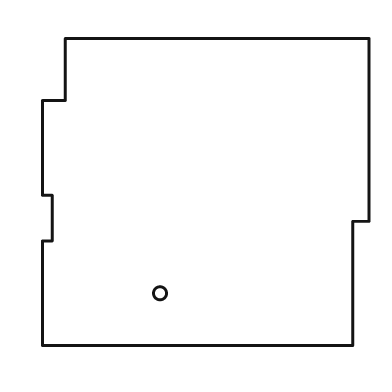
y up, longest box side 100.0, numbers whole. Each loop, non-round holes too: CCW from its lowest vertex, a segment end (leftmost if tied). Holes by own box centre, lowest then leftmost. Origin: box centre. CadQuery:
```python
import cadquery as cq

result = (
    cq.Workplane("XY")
    .moveTo(-50.0, -47.0)
    .lineTo(45.0, -47.0)
    .lineTo(45.0, -9.0)
    .lineTo(50.0, -9.0)
    .lineTo(50.0, 47.0)
    .lineTo(-43.0, 47.0)
    .lineTo(-43.0, 28.0)
    .lineTo(-50.0, 28.0)
    .lineTo(-50.0, -1.0)
    .lineTo(-47.0, -1.0)
    .lineTo(-47.0, -15.0)
    .lineTo(-50.0, -15.0)
    .close()
    .moveTo(-14.0, -31.0)
    .circle(2.0)
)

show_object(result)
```